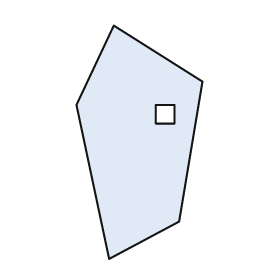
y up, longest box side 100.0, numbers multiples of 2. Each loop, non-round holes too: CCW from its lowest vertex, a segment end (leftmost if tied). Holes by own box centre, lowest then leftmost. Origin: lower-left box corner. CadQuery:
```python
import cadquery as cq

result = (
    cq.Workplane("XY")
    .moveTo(14.0, 0.0)
    .lineTo(44.0, 16.0)
    .lineTo(54.0, 76.0)
    .lineTo(16.0, 100.0)
    .lineTo(0.0, 66.0)
    .close()
    .moveTo(34.0, 58.0)
    .lineTo(42.0, 58.0)
    .lineTo(42.0, 66.0)
    .lineTo(34.0, 66.0)
    .close()
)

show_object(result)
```